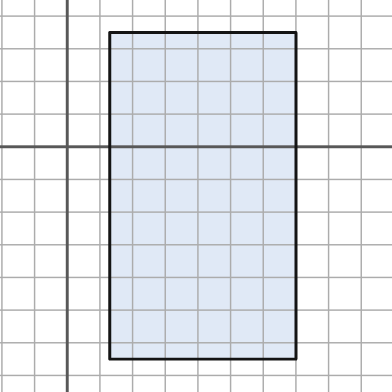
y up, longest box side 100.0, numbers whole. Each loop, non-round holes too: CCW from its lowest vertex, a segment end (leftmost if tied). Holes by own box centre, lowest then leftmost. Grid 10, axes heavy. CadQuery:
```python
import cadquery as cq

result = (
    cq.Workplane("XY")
    .moveTo(13.0, -65.0)
    .lineTo(70.0, -65.0)
    .lineTo(70.0, 35.0)
    .lineTo(13.0, 35.0)
    .close()
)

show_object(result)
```